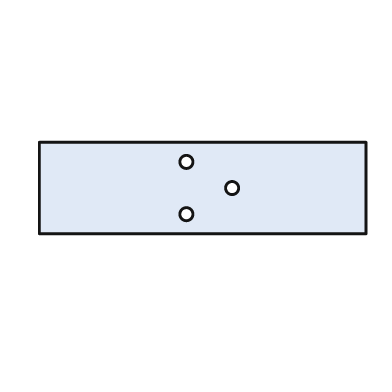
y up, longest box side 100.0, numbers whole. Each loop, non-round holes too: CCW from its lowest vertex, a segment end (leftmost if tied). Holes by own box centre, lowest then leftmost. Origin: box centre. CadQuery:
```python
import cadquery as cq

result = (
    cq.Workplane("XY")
    .moveTo(-50.0, -14.0)
    .lineTo(50.0, -14.0)
    .lineTo(50.0, 14.0)
    .lineTo(-50.0, 14.0)
    .close()
    .moveTo(-5.0, -8.0)
    .circle(2.0)
    .moveTo(9.0, 0.0)
    .circle(2.0)
    .moveTo(-5.0, 8.0)
    .circle(2.0)
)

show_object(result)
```